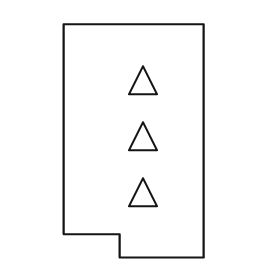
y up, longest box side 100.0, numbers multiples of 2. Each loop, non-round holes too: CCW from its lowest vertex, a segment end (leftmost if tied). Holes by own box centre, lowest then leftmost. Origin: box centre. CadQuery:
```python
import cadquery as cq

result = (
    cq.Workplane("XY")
    .moveTo(-6.0, -50.0)
    .lineTo(30.0, -50.0)
    .lineTo(30.0, 50.0)
    .lineTo(-30.0, 50.0)
    .lineTo(-30.0, -40.0)
    .lineTo(-6.0, -40.0)
    .close()
    .moveTo(-2.0, -28.0)
    .lineTo(10.0, -28.0)
    .lineTo(4.0, -16.0)
    .close()
    .moveTo(-2.0, -4.0)
    .lineTo(10.0, -4.0)
    .lineTo(4.0, 8.0)
    .close()
    .moveTo(-2.0, 20.0)
    .lineTo(10.0, 20.0)
    .lineTo(4.0, 32.0)
    .close()
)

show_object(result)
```